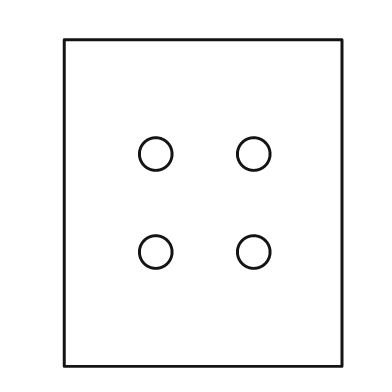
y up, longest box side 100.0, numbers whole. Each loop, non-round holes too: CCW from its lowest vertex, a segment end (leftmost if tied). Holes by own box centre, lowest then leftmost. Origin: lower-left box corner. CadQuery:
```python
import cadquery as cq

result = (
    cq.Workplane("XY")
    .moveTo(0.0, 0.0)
    .lineTo(85.0, 0.0)
    .lineTo(85.0, 100.0)
    .lineTo(0.0, 100.0)
    .close()
    .moveTo(28.0, 35.0)
    .circle(5.0)
    .moveTo(58.0, 35.0)
    .circle(5.0)
    .moveTo(28.0, 65.0)
    .circle(5.0)
    .moveTo(58.0, 65.0)
    .circle(5.0)
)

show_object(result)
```